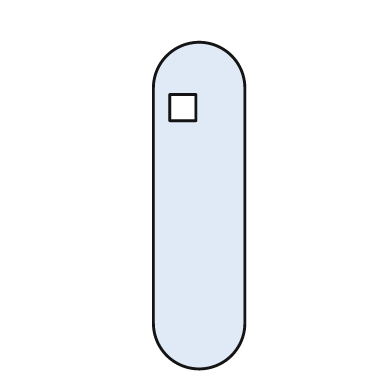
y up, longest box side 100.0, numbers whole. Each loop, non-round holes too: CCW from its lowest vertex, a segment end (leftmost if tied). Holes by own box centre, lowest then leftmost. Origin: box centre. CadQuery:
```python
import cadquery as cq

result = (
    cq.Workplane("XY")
    .moveTo(-14.0, -36.0)
    .threePointArc((0.0, -50.0), (14.0, -36.0))
    .lineTo(14.0, 36.0)
    .threePointArc((0.0, 50.0), (-14.0, 36.0))
    .close()
    .moveTo(-9.0, 26.0)
    .lineTo(-1.0, 26.0)
    .lineTo(-1.0, 34.0)
    .lineTo(-9.0, 34.0)
    .close()
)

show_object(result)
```